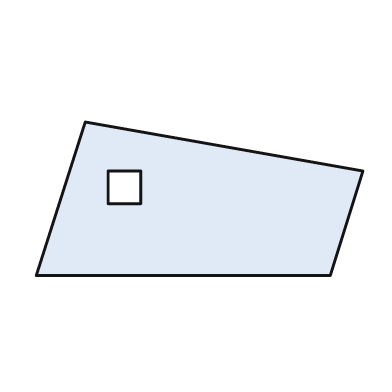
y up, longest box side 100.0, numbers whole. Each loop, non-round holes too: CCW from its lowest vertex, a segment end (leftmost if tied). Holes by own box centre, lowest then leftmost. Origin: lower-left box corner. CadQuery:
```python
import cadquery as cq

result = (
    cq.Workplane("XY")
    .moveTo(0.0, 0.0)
    .lineTo(90.0, 0.0)
    .lineTo(100.0, 32.0)
    .lineTo(15.0, 47.0)
    .close()
    .moveTo(22.0, 22.0)
    .lineTo(32.0, 22.0)
    .lineTo(32.0, 32.0)
    .lineTo(22.0, 32.0)
    .close()
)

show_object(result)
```